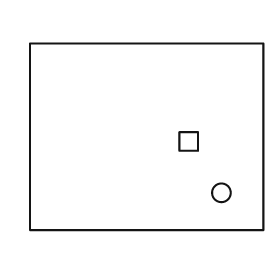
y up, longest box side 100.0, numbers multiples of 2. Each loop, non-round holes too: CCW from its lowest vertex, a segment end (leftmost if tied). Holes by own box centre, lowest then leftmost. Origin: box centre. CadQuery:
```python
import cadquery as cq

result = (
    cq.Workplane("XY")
    .moveTo(-50.0, -40.0)
    .lineTo(50.0, -40.0)
    .lineTo(50.0, 40.0)
    .lineTo(-50.0, 40.0)
    .close()
    .moveTo(32.0, -24.0)
    .circle(4.0)
    .moveTo(14.0, -6.0)
    .lineTo(22.0, -6.0)
    .lineTo(22.0, 2.0)
    .lineTo(14.0, 2.0)
    .close()
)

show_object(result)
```